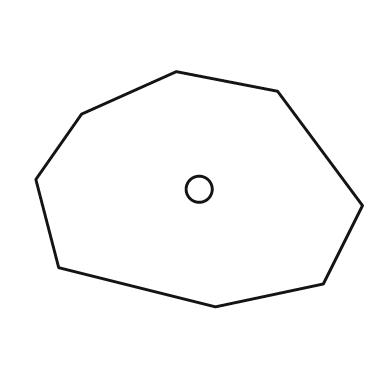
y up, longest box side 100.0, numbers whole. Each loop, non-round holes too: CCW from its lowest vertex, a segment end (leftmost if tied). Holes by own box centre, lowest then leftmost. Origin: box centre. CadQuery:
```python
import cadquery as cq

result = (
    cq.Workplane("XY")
    .moveTo(5.0, -36.0)
    .lineTo(38.0, -29.0)
    .lineTo(50.0, -5.0)
    .lineTo(24.0, 30.0)
    .lineTo(-7.0, 36.0)
    .lineTo(-36.0, 23.0)
    .lineTo(-50.0, 3.0)
    .lineTo(-43.0, -24.0)
    .close()
    .moveTo(0.0, 0.0)
    .circle(4.0)
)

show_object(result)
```